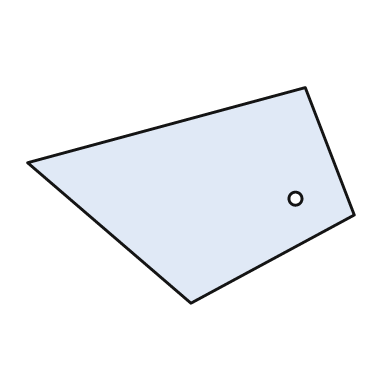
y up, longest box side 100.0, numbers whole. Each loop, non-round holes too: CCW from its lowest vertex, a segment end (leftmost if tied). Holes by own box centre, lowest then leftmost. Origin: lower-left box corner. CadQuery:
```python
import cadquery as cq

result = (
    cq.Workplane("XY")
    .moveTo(50.0, 0.0)
    .lineTo(100.0, 27.0)
    .lineTo(85.0, 66.0)
    .lineTo(0.0, 43.0)
    .close()
    .moveTo(82.0, 32.0)
    .circle(2.0)
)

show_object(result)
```